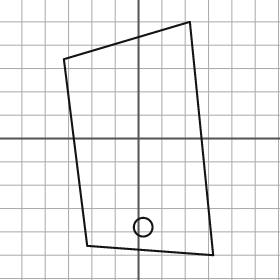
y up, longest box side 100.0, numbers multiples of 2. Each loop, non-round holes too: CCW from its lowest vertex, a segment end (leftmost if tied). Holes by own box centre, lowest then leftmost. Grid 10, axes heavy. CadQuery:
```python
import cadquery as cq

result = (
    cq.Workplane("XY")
    .moveTo(32.0, -50.0)
    .lineTo(22.0, 50.0)
    .lineTo(-32.0, 34.0)
    .lineTo(-22.0, -46.0)
    .close()
    .moveTo(2.0, -38.0)
    .circle(4.0)
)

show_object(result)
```